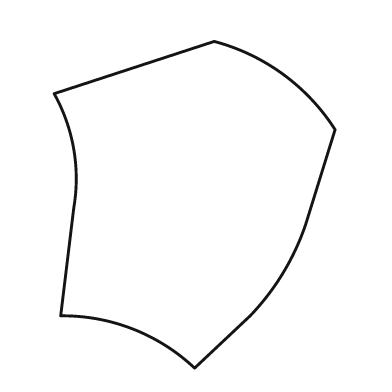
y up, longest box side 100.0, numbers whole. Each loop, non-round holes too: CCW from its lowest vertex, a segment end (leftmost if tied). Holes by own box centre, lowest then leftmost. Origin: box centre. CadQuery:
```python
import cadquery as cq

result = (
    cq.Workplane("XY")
    .moveTo(0.0, -50.0)
    .lineTo(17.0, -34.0)
    .threePointArc((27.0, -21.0), (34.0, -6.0))
    .lineTo(43.0, 23.0)
    .threePointArc((27.0, 40.0), (6.0, 50.0))
    .lineTo(-43.0, 34.0)
    .threePointArc((-37.0, 17.0), (-37.0, -1.0))
    .lineTo(-41.0, -34.0)
    .threePointArc((-19.0, -38.0), (0.0, -50.0))
    .close()
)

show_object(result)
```